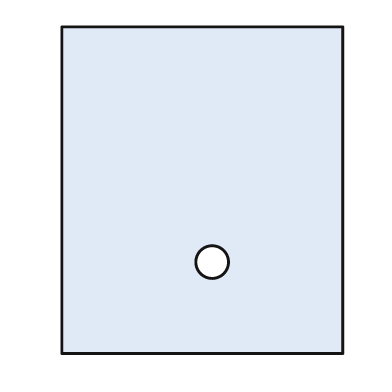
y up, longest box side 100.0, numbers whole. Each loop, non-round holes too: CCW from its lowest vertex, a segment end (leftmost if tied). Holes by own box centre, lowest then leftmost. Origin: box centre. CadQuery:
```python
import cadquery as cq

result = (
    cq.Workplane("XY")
    .moveTo(-43.0, -50.0)
    .lineTo(43.0, -50.0)
    .lineTo(43.0, 50.0)
    .lineTo(-43.0, 50.0)
    .close()
    .moveTo(3.0, -22.0)
    .circle(5.0)
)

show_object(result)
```